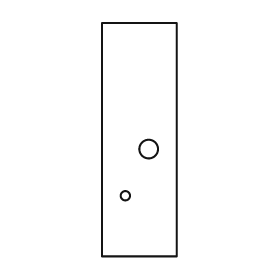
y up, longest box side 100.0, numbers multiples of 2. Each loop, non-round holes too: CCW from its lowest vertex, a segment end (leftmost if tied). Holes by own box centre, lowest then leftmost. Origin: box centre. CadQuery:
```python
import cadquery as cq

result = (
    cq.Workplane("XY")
    .moveTo(-16.0, -50.0)
    .lineTo(16.0, -50.0)
    .lineTo(16.0, 50.0)
    .lineTo(-16.0, 50.0)
    .close()
    .moveTo(-6.0, -24.0)
    .circle(2.0)
    .moveTo(4.0, -4.0)
    .circle(4.0)
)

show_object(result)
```